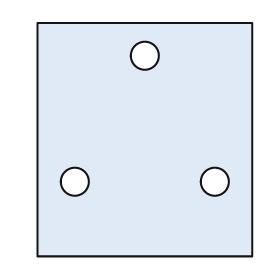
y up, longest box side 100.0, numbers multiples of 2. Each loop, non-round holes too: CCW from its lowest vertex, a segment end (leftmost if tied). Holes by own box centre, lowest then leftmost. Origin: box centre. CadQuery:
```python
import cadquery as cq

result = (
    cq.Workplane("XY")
    .moveTo(-46.0, -50.0)
    .lineTo(46.0, -50.0)
    .lineTo(46.0, 50.0)
    .lineTo(-46.0, 50.0)
    .close()
    .moveTo(-30.0, -18.0)
    .circle(6.0)
    .moveTo(30.0, -18.0)
    .circle(6.0)
    .moveTo(0.0, 36.0)
    .circle(6.0)
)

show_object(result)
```